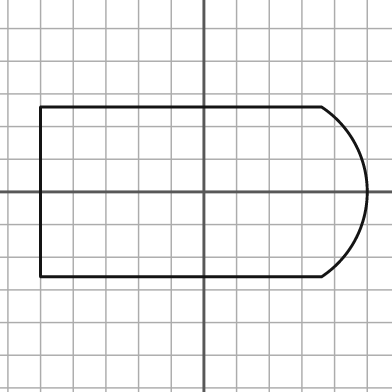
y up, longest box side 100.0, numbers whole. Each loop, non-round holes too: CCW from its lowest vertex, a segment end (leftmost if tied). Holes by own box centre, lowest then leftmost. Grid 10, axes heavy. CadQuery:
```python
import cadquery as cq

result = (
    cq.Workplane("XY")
    .moveTo(-50.0, -26.0)
    .lineTo(36.0, -26.0)
    .threePointArc((50.0, 0.0), (36.0, 26.0))
    .lineTo(-50.0, 26.0)
    .close()
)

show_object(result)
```